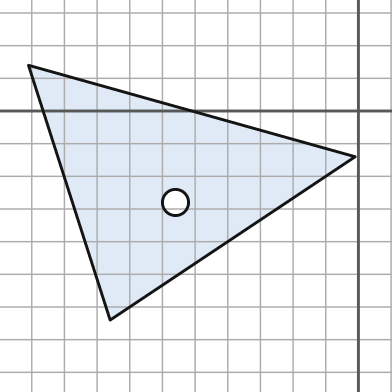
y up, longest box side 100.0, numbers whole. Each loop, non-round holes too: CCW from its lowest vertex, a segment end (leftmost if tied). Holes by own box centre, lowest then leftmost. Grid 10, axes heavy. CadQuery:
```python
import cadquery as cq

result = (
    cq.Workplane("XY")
    .moveTo(-76.0, -64.0)
    .lineTo(-1.0, -14.0)
    .lineTo(-101.0, 14.0)
    .close()
    .moveTo(-56.0, -28.0)
    .circle(4.0)
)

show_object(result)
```